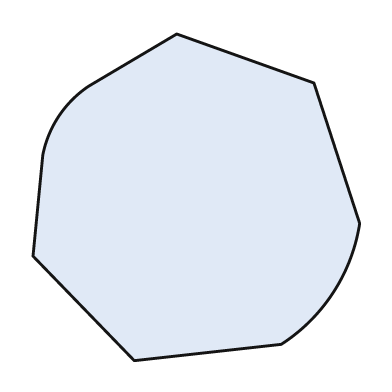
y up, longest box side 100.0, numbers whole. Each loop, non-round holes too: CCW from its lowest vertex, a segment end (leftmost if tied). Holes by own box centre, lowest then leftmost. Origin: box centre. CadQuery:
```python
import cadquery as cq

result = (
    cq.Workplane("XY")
    .moveTo(-19.0, -50.0)
    .lineTo(26.0, -45.0)
    .threePointArc((42.0, -29.0), (50.0, -8.0))
    .lineTo(36.0, 35.0)
    .lineTo(-6.0, 50.0)
    .lineTo(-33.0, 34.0)
    .threePointArc((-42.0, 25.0), (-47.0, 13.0))
    .lineTo(-50.0, -18.0)
    .close()
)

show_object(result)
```